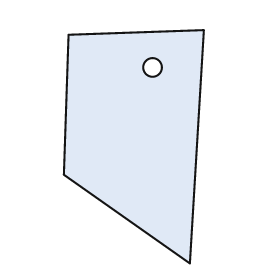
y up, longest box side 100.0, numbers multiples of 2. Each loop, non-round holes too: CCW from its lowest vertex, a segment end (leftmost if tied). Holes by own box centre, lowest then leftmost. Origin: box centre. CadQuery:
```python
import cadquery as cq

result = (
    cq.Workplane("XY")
    .moveTo(24.0, -50.0)
    .lineTo(30.0, 50.0)
    .lineTo(-28.0, 48.0)
    .lineTo(-30.0, -12.0)
    .close()
    .moveTo(8.0, 34.0)
    .circle(4.0)
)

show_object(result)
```